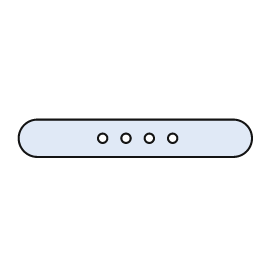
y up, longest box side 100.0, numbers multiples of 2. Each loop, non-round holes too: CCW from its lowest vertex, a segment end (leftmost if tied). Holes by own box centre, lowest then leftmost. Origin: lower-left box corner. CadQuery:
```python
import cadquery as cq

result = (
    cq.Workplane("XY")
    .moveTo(8.0, 0.0)
    .lineTo(92.0, 0.0)
    .threePointArc((100.0, 8.0), (92.0, 16.0))
    .lineTo(8.0, 16.0)
    .threePointArc((0.0, 8.0), (8.0, 0.0))
    .close()
    .moveTo(36.0, 8.0)
    .circle(2.0)
    .moveTo(46.0, 8.0)
    .circle(2.0)
    .moveTo(56.0, 8.0)
    .circle(2.0)
    .moveTo(66.0, 8.0)
    .circle(2.0)
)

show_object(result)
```